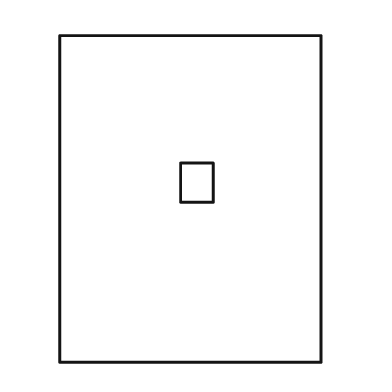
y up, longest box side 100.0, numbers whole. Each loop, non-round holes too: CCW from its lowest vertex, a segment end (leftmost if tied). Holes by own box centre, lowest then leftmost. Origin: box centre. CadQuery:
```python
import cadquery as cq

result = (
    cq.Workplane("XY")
    .moveTo(-40.0, -50.0)
    .lineTo(40.0, -50.0)
    .lineTo(40.0, 50.0)
    .lineTo(-40.0, 50.0)
    .close()
    .moveTo(-3.0, -1.0)
    .lineTo(7.0, -1.0)
    .lineTo(7.0, 11.0)
    .lineTo(-3.0, 11.0)
    .close()
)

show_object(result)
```